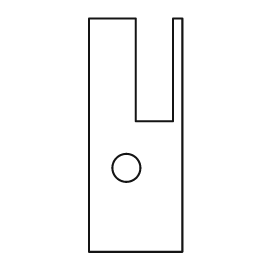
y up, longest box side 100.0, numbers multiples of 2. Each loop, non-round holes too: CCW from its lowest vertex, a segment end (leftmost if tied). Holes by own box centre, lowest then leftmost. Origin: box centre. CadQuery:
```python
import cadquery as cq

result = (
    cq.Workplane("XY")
    .moveTo(-20.0, -50.0)
    .lineTo(20.0, -50.0)
    .lineTo(20.0, 50.0)
    .lineTo(16.0, 50.0)
    .lineTo(16.0, 6.0)
    .lineTo(0.0, 6.0)
    .lineTo(0.0, 50.0)
    .lineTo(-20.0, 50.0)
    .close()
    .moveTo(-4.0, -14.0)
    .circle(6.0)
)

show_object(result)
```